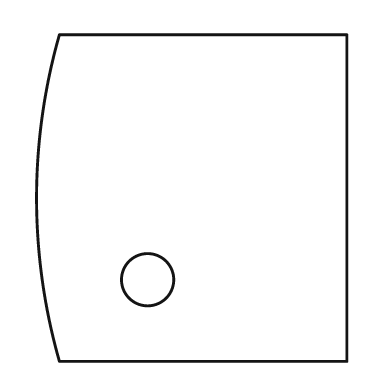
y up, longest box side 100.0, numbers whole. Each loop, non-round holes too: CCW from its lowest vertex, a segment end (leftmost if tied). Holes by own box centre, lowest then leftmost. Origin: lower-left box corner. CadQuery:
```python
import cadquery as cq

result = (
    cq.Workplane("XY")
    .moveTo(7.0, 0.0)
    .lineTo(95.0, 0.0)
    .lineTo(95.0, 100.0)
    .lineTo(7.0, 100.0)
    .threePointArc((0.0, 50.0), (7.0, 0.0))
    .close()
    .moveTo(34.0, 25.0)
    .circle(8.0)
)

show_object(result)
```